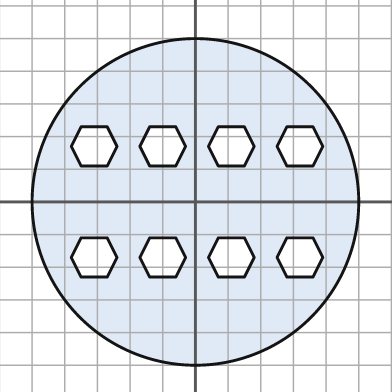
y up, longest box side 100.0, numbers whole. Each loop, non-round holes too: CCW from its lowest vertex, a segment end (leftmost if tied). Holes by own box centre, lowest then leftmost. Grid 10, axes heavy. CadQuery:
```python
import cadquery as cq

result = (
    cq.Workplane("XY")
    .moveTo(0.0, 0.0)
    .circle(50.0)
    .moveTo(-35.0, -23.0)
    .lineTo(-27.0, -23.0)
    .lineTo(-24.0, -17.0)
    .lineTo(-27.0, -11.0)
    .lineTo(-35.0, -11.0)
    .lineTo(-38.0, -17.0)
    .close()
    .moveTo(-14.0, -23.0)
    .lineTo(-6.0, -23.0)
    .lineTo(-3.0, -17.0)
    .lineTo(-6.0, -11.0)
    .lineTo(-14.0, -11.0)
    .lineTo(-17.0, -17.0)
    .close()
    .moveTo(7.0, -23.0)
    .lineTo(15.0, -23.0)
    .lineTo(18.0, -17.0)
    .lineTo(15.0, -11.0)
    .lineTo(7.0, -11.0)
    .lineTo(4.0, -17.0)
    .close()
    .moveTo(28.0, -23.0)
    .lineTo(36.0, -23.0)
    .lineTo(39.0, -17.0)
    .lineTo(36.0, -11.0)
    .lineTo(28.0, -11.0)
    .lineTo(25.0, -17.0)
    .close()
    .moveTo(-35.0, 11.0)
    .lineTo(-27.0, 11.0)
    .lineTo(-24.0, 17.0)
    .lineTo(-27.0, 23.0)
    .lineTo(-35.0, 23.0)
    .lineTo(-38.0, 17.0)
    .close()
    .moveTo(-14.0, 11.0)
    .lineTo(-6.0, 11.0)
    .lineTo(-3.0, 17.0)
    .lineTo(-6.0, 23.0)
    .lineTo(-14.0, 23.0)
    .lineTo(-17.0, 17.0)
    .close()
    .moveTo(7.0, 11.0)
    .lineTo(15.0, 11.0)
    .lineTo(18.0, 17.0)
    .lineTo(15.0, 23.0)
    .lineTo(7.0, 23.0)
    .lineTo(4.0, 17.0)
    .close()
    .moveTo(28.0, 11.0)
    .lineTo(36.0, 11.0)
    .lineTo(39.0, 17.0)
    .lineTo(36.0, 23.0)
    .lineTo(28.0, 23.0)
    .lineTo(25.0, 17.0)
    .close()
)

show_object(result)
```